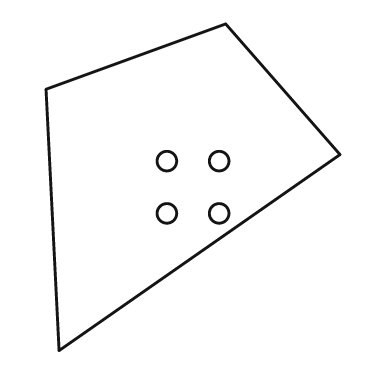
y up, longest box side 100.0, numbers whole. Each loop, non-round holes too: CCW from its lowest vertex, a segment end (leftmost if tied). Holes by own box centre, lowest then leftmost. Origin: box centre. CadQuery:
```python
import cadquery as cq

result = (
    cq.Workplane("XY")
    .moveTo(-41.0, -50.0)
    .lineTo(45.0, 10.0)
    .lineTo(10.0, 50.0)
    .lineTo(-45.0, 30.0)
    .close()
    .moveTo(-8.0, -8.0)
    .circle(3.0)
    .moveTo(8.0, -8.0)
    .circle(3.0)
    .moveTo(-8.0, 8.0)
    .circle(3.0)
    .moveTo(8.0, 8.0)
    .circle(3.0)
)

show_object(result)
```